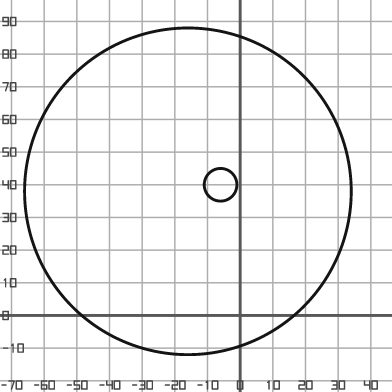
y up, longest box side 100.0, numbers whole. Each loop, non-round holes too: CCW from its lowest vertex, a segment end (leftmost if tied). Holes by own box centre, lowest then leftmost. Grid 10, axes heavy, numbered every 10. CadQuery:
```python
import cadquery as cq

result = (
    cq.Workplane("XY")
    .moveTo(-16.0, 38.0)
    .circle(50.0)
    .moveTo(-6.0, 40.0)
    .circle(5.0)
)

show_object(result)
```